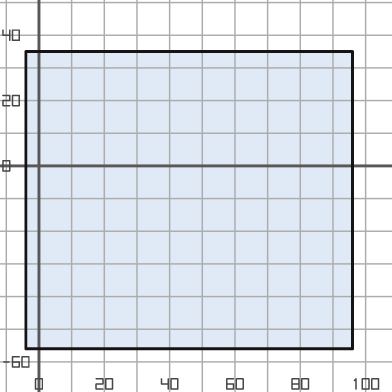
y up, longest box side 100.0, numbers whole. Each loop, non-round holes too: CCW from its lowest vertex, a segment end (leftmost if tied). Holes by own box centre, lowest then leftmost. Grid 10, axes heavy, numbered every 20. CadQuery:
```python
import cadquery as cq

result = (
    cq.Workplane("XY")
    .moveTo(-4.0, -56.0)
    .lineTo(96.0, -56.0)
    .lineTo(96.0, 35.0)
    .lineTo(-4.0, 35.0)
    .close()
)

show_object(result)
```